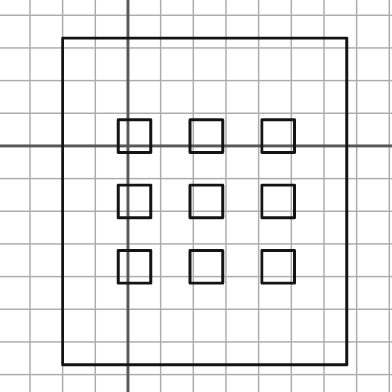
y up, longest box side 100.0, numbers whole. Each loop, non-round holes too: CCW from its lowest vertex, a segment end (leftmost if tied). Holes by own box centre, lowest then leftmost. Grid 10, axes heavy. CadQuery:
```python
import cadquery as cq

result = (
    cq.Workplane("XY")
    .moveTo(-20.0, -67.0)
    .lineTo(67.0, -67.0)
    .lineTo(67.0, 33.0)
    .lineTo(-20.0, 33.0)
    .close()
    .moveTo(-3.0, -42.0)
    .lineTo(7.0, -42.0)
    .lineTo(7.0, -32.0)
    .lineTo(-3.0, -32.0)
    .close()
    .moveTo(19.0, -42.0)
    .lineTo(29.0, -42.0)
    .lineTo(29.0, -32.0)
    .lineTo(19.0, -32.0)
    .close()
    .moveTo(41.0, -42.0)
    .lineTo(51.0, -42.0)
    .lineTo(51.0, -32.0)
    .lineTo(41.0, -32.0)
    .close()
    .moveTo(-3.0, -22.0)
    .lineTo(7.0, -22.0)
    .lineTo(7.0, -12.0)
    .lineTo(-3.0, -12.0)
    .close()
    .moveTo(19.0, -22.0)
    .lineTo(29.0, -22.0)
    .lineTo(29.0, -12.0)
    .lineTo(19.0, -12.0)
    .close()
    .moveTo(41.0, -22.0)
    .lineTo(51.0, -22.0)
    .lineTo(51.0, -12.0)
    .lineTo(41.0, -12.0)
    .close()
    .moveTo(-3.0, -2.0)
    .lineTo(7.0, -2.0)
    .lineTo(7.0, 8.0)
    .lineTo(-3.0, 8.0)
    .close()
    .moveTo(19.0, -2.0)
    .lineTo(29.0, -2.0)
    .lineTo(29.0, 8.0)
    .lineTo(19.0, 8.0)
    .close()
    .moveTo(41.0, -2.0)
    .lineTo(51.0, -2.0)
    .lineTo(51.0, 8.0)
    .lineTo(41.0, 8.0)
    .close()
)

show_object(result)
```